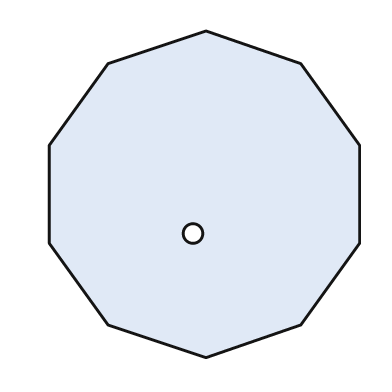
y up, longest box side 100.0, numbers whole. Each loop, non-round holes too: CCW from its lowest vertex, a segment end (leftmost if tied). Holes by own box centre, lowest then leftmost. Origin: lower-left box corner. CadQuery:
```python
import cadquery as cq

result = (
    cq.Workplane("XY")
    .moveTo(48.0, 0.0)
    .lineTo(77.0, 10.0)
    .lineTo(95.0, 35.0)
    .lineTo(95.0, 65.0)
    .lineTo(77.0, 90.0)
    .lineTo(48.0, 100.0)
    .lineTo(18.0, 90.0)
    .lineTo(0.0, 65.0)
    .lineTo(0.0, 35.0)
    .lineTo(18.0, 10.0)
    .close()
    .moveTo(44.0, 38.0)
    .circle(3.0)
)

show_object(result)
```